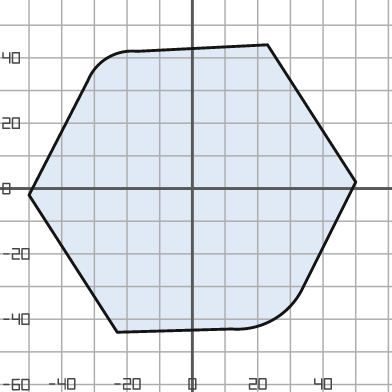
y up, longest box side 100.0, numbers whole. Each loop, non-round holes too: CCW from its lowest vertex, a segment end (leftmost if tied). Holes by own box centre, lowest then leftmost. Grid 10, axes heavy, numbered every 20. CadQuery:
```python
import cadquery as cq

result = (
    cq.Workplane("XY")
    .moveTo(-23.0, -44.0)
    .lineTo(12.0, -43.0)
    .threePointArc((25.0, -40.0), (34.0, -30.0))
    .lineTo(50.0, 2.0)
    .lineTo(23.0, 44.0)
    .lineTo(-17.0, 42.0)
    .threePointArc((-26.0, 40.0), (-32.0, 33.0))
    .lineTo(-50.0, -2.0)
    .close()
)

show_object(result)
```